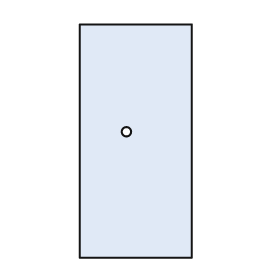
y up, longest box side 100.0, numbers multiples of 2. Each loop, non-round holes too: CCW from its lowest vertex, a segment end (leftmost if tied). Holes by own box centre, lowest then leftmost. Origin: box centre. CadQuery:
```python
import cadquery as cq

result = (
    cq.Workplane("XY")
    .moveTo(-24.0, -50.0)
    .lineTo(24.0, -50.0)
    .lineTo(24.0, 50.0)
    .lineTo(-24.0, 50.0)
    .close()
    .moveTo(-4.0, 4.0)
    .circle(2.0)
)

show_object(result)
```